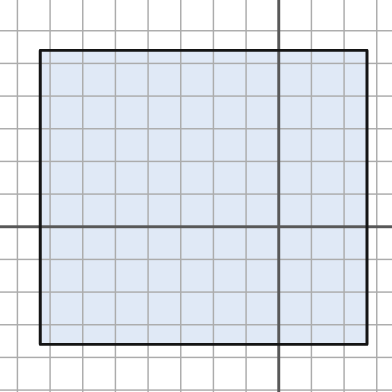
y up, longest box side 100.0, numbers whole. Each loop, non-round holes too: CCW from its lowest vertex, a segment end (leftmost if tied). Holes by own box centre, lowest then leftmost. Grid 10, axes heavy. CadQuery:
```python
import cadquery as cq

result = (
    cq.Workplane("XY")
    .moveTo(-73.0, -36.0)
    .lineTo(27.0, -36.0)
    .lineTo(27.0, 54.0)
    .lineTo(-73.0, 54.0)
    .close()
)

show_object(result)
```